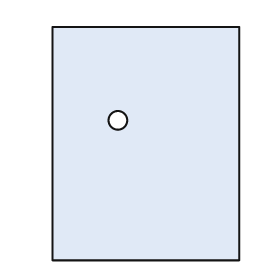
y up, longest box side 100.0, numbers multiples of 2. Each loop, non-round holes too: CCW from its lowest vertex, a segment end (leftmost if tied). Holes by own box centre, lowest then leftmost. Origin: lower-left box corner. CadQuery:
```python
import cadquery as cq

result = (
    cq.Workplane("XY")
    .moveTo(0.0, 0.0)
    .lineTo(80.0, 0.0)
    .lineTo(80.0, 100.0)
    .lineTo(0.0, 100.0)
    .close()
    .moveTo(28.0, 60.0)
    .circle(4.0)
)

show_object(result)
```